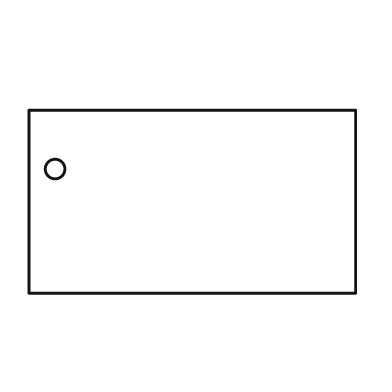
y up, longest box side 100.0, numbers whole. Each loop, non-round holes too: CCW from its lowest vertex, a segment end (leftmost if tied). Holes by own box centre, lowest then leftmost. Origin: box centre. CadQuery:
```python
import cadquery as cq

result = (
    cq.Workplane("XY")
    .moveTo(-50.0, -28.0)
    .lineTo(50.0, -28.0)
    .lineTo(50.0, 28.0)
    .lineTo(-50.0, 28.0)
    .close()
    .moveTo(-42.0, 10.0)
    .circle(3.0)
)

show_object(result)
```